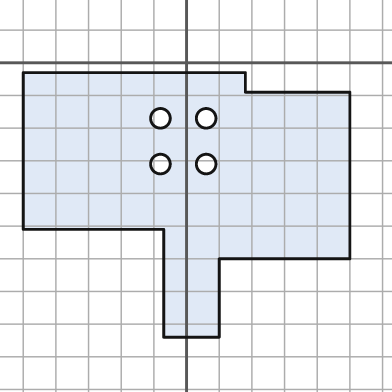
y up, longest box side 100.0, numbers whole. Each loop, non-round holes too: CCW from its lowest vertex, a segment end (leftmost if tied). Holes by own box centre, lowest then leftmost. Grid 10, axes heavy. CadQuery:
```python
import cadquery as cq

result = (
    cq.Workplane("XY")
    .moveTo(-7.0, -84.0)
    .lineTo(10.0, -84.0)
    .lineTo(10.0, -60.0)
    .lineTo(50.0, -60.0)
    .lineTo(50.0, -9.0)
    .lineTo(18.0, -9.0)
    .lineTo(18.0, -3.0)
    .lineTo(-50.0, -3.0)
    .lineTo(-50.0, -51.0)
    .lineTo(-7.0, -51.0)
    .close()
    .moveTo(-8.0, -31.0)
    .circle(3.0)
    .moveTo(6.0, -31.0)
    .circle(3.0)
    .moveTo(-8.0, -17.0)
    .circle(3.0)
    .moveTo(6.0, -17.0)
    .circle(3.0)
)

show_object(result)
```